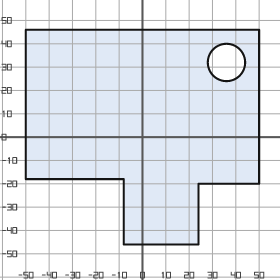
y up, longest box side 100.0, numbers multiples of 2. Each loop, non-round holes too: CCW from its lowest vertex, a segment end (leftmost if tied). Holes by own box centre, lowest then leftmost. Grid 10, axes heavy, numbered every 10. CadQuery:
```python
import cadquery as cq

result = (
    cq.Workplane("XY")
    .moveTo(-8.0, -46.0)
    .lineTo(24.0, -46.0)
    .lineTo(24.0, -20.0)
    .lineTo(50.0, -20.0)
    .lineTo(50.0, 46.0)
    .lineTo(-50.0, 46.0)
    .lineTo(-50.0, -18.0)
    .lineTo(-8.0, -18.0)
    .close()
    .moveTo(36.0, 32.0)
    .circle(8.0)
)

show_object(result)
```